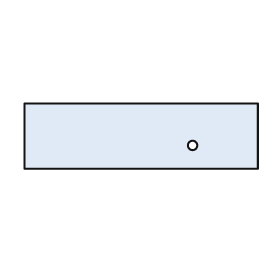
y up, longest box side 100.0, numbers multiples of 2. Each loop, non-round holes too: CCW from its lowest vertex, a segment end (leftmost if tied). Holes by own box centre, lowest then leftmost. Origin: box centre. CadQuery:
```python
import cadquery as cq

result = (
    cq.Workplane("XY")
    .moveTo(-50.0, -14.0)
    .lineTo(50.0, -14.0)
    .lineTo(50.0, 14.0)
    .lineTo(-50.0, 14.0)
    .close()
    .moveTo(22.0, -4.0)
    .circle(2.0)
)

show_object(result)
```